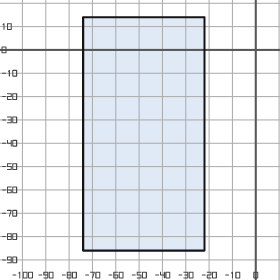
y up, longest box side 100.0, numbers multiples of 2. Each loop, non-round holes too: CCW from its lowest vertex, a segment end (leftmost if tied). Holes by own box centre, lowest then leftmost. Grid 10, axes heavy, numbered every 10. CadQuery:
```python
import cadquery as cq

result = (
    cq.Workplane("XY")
    .moveTo(-74.0, -86.0)
    .lineTo(-22.0, -86.0)
    .lineTo(-22.0, 14.0)
    .lineTo(-74.0, 14.0)
    .close()
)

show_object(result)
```